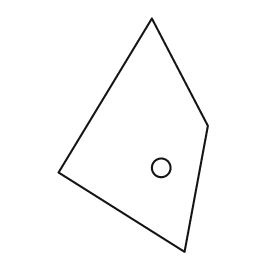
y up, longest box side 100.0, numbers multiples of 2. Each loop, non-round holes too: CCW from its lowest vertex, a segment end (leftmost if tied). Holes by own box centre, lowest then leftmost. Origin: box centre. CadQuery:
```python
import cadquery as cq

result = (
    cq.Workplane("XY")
    .moveTo(22.0, -50.0)
    .lineTo(32.0, 4.0)
    .lineTo(8.0, 50.0)
    .lineTo(-32.0, -16.0)
    .close()
    .moveTo(12.0, -14.0)
    .circle(4.0)
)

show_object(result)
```